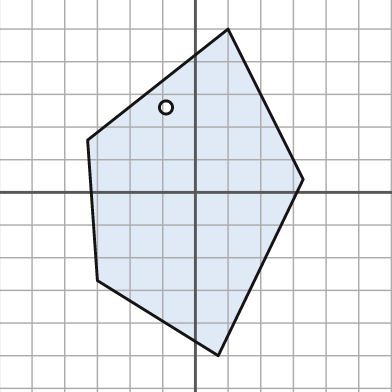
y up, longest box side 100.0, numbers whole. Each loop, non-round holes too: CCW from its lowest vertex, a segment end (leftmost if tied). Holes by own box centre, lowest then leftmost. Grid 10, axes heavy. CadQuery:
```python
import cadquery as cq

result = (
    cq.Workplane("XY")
    .moveTo(7.0, -50.0)
    .lineTo(33.0, 4.0)
    .lineTo(10.0, 50.0)
    .lineTo(-33.0, 16.0)
    .lineTo(-30.0, -27.0)
    .close()
    .moveTo(-9.0, 26.0)
    .circle(2.0)
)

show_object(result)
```